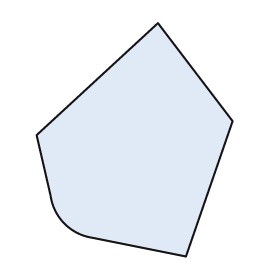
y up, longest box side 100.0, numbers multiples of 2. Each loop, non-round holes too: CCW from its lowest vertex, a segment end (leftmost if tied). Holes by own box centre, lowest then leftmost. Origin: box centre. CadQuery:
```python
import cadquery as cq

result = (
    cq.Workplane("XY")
    .moveTo(22.0, -50.0)
    .lineTo(42.0, 8.0)
    .lineTo(10.0, 50.0)
    .lineTo(-42.0, 2.0)
    .lineTo(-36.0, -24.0)
    .threePointArc((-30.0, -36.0), (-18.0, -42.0))
    .close()
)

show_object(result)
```